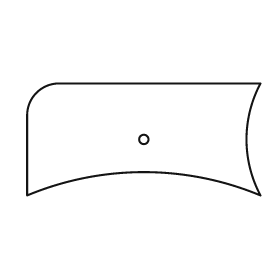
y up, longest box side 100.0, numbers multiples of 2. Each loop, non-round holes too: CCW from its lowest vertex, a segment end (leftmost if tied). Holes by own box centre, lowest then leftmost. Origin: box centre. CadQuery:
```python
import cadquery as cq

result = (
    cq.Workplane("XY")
    .moveTo(-50.0, -24.0)
    .threePointArc((0.0, -14.0), (50.0, -24.0))
    .threePointArc((44.0, 0.0), (50.0, 24.0))
    .lineTo(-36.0, 24.0)
    .threePointArc((-46.0, 20.0), (-50.0, 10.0))
    .close()
    .moveTo(0.0, 0.0)
    .circle(2.0)
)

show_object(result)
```